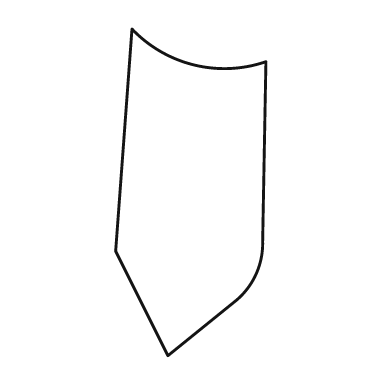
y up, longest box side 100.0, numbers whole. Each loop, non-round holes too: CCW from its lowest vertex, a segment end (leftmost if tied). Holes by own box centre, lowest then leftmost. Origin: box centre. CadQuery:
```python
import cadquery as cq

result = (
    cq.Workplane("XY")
    .moveTo(-7.0, -50.0)
    .lineTo(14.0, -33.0)
    .threePointArc((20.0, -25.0), (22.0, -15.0))
    .lineTo(23.0, 40.0)
    .threePointArc((1.0, 39.0), (-18.0, 50.0))
    .lineTo(-23.0, -18.0)
    .close()
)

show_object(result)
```